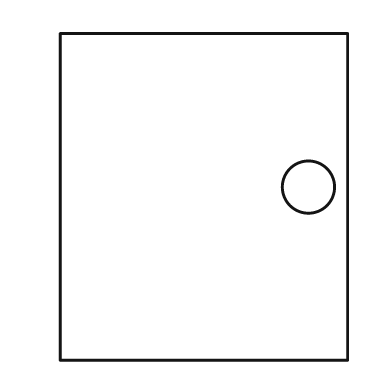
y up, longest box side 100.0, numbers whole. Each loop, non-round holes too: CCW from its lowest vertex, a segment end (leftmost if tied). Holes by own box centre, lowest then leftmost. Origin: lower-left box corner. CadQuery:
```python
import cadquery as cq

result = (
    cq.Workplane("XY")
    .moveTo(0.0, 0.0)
    .lineTo(88.0, 0.0)
    .lineTo(88.0, 100.0)
    .lineTo(0.0, 100.0)
    .close()
    .moveTo(76.0, 53.0)
    .circle(8.0)
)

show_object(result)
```